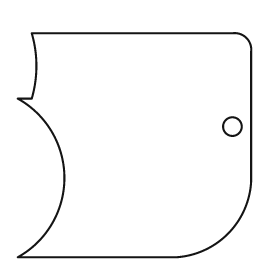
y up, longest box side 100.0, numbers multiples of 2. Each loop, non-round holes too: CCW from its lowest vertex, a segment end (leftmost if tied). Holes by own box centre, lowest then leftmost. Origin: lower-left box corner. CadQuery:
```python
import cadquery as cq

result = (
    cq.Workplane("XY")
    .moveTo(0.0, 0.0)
    .lineTo(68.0, 0.0)
    .threePointArc((90.0, 10.0), (100.0, 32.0))
    .lineTo(100.0, 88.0)
    .threePointArc((98.0, 94.0), (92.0, 96.0))
    .lineTo(6.0, 96.0)
    .threePointArc((8.0, 82.0), (6.0, 68.0))
    .lineTo(0.0, 68.0)
    .threePointArc((20.0, 34.0), (0.0, 0.0))
    .close()
    .moveTo(92.0, 56.0)
    .circle(4.0)
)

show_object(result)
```